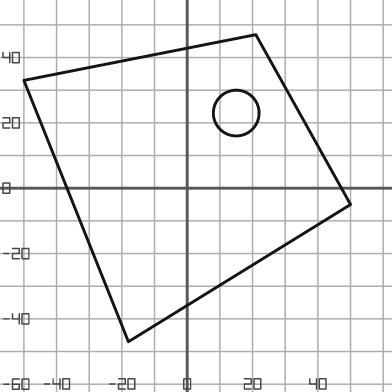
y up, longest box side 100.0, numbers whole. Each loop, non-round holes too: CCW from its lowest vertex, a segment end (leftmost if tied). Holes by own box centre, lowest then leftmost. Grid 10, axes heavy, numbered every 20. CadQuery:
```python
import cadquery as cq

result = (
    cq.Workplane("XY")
    .moveTo(-18.0, -47.0)
    .lineTo(50.0, -5.0)
    .lineTo(21.0, 47.0)
    .lineTo(-50.0, 33.0)
    .close()
    .moveTo(15.0, 23.0)
    .circle(7.0)
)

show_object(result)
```